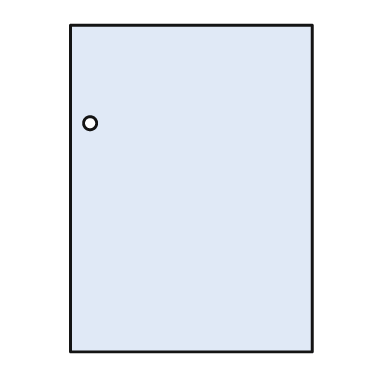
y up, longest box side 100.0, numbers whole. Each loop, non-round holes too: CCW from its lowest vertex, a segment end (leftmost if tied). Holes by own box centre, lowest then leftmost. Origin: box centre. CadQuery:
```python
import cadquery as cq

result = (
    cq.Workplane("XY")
    .moveTo(-37.0, -50.0)
    .lineTo(37.0, -50.0)
    .lineTo(37.0, 50.0)
    .lineTo(-37.0, 50.0)
    .close()
    .moveTo(-31.0, 20.0)
    .circle(2.0)
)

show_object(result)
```